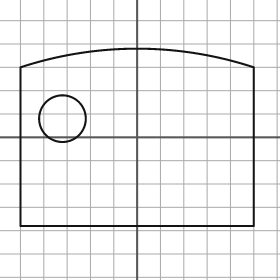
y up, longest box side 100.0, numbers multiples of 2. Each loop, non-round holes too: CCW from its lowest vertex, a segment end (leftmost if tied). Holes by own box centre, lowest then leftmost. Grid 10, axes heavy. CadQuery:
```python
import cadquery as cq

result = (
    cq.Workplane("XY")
    .moveTo(-50.0, -38.0)
    .lineTo(50.0, -38.0)
    .lineTo(50.0, 30.0)
    .threePointArc((0.0, 38.0), (-50.0, 30.0))
    .close()
    .moveTo(-32.0, 8.0)
    .circle(10.0)
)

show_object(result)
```